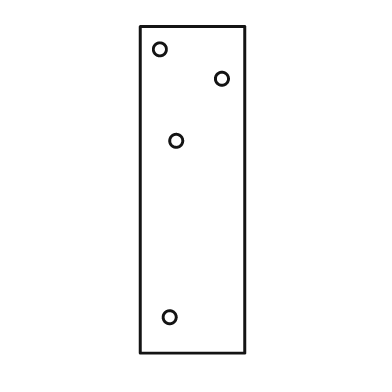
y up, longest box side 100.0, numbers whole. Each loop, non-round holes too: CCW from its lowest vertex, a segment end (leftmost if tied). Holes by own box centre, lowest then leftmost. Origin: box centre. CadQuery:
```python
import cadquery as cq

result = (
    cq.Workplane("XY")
    .moveTo(-16.0, -50.0)
    .lineTo(16.0, -50.0)
    .lineTo(16.0, 50.0)
    .lineTo(-16.0, 50.0)
    .close()
    .moveTo(-7.0, -39.0)
    .circle(2.0)
    .moveTo(-5.0, 15.0)
    .circle(2.0)
    .moveTo(9.0, 34.0)
    .circle(2.0)
    .moveTo(-10.0, 43.0)
    .circle(2.0)
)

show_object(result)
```